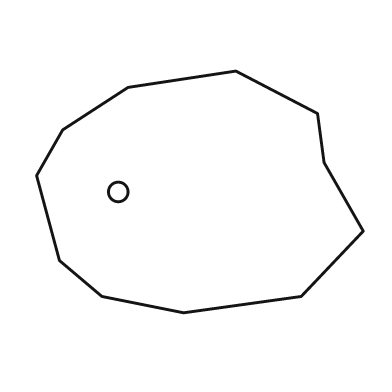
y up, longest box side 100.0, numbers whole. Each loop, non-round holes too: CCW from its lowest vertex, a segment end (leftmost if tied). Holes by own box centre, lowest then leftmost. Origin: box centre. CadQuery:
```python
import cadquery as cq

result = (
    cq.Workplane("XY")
    .moveTo(-5.0, -37.0)
    .lineTo(31.0, -32.0)
    .lineTo(50.0, -12.0)
    .lineTo(38.0, 9.0)
    .lineTo(36.0, 24.0)
    .lineTo(11.0, 37.0)
    .lineTo(-22.0, 32.0)
    .lineTo(-42.0, 19.0)
    .lineTo(-50.0, 5.0)
    .lineTo(-43.0, -21.0)
    .lineTo(-30.0, -32.0)
    .close()
    .moveTo(-25.0, 0.0)
    .circle(3.0)
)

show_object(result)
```